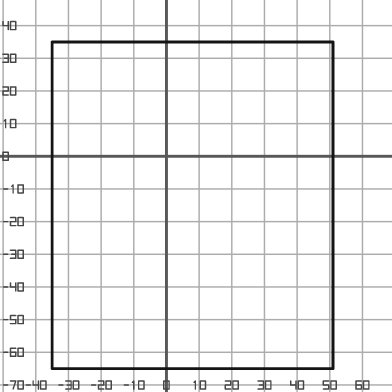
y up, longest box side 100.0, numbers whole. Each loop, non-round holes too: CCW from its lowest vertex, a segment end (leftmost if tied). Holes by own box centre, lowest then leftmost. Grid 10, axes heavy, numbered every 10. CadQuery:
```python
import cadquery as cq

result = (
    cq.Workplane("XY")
    .moveTo(-35.0, -65.0)
    .lineTo(51.0, -65.0)
    .lineTo(51.0, 35.0)
    .lineTo(-35.0, 35.0)
    .close()
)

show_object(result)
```